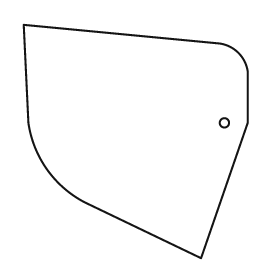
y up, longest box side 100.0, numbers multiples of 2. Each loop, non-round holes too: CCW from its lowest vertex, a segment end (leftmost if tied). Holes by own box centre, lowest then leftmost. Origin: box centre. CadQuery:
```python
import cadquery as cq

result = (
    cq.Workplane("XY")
    .moveTo(28.0, -50.0)
    .lineTo(48.0, 8.0)
    .lineTo(48.0, 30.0)
    .threePointArc((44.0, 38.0), (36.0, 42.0))
    .lineTo(-48.0, 50.0)
    .lineTo(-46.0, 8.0)
    .threePointArc((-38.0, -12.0), (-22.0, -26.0))
    .close()
    .moveTo(38.0, 8.0)
    .circle(2.0)
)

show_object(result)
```